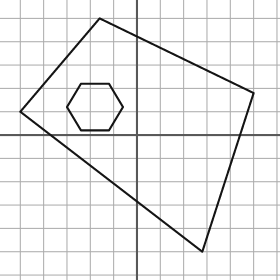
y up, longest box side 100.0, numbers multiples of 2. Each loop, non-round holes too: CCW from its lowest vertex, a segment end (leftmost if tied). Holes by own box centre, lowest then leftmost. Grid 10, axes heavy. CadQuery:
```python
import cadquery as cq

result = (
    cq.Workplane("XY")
    .moveTo(28.0, -50.0)
    .lineTo(50.0, 18.0)
    .lineTo(-16.0, 50.0)
    .lineTo(-50.0, 10.0)
    .close()
    .moveTo(-24.0, 2.0)
    .lineTo(-12.0, 2.0)
    .lineTo(-6.0, 12.0)
    .lineTo(-12.0, 22.0)
    .lineTo(-24.0, 22.0)
    .lineTo(-30.0, 12.0)
    .close()
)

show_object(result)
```